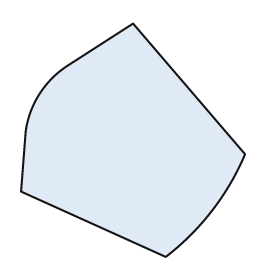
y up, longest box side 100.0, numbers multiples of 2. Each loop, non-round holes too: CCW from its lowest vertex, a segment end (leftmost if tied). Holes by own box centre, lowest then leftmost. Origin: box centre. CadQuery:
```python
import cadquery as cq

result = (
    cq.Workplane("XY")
    .moveTo(14.0, -50.0)
    .threePointArc((34.0, -30.0), (48.0, -6.0))
    .lineTo(0.0, 50.0)
    .lineTo(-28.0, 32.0)
    .threePointArc((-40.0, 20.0), (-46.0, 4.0))
    .lineTo(-48.0, -22.0)
    .close()
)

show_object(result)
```